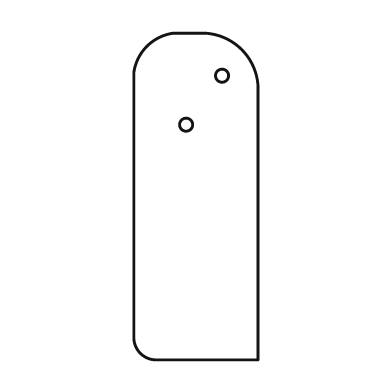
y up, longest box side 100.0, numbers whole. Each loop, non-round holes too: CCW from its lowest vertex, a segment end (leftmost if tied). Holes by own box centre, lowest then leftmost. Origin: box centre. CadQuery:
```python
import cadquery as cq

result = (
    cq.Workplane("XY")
    .moveTo(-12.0, -50.0)
    .lineTo(19.0, -50.0)
    .lineTo(19.0, 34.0)
    .threePointArc((14.0, 45.0), (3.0, 50.0))
    .lineTo(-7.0, 50.0)
    .threePointArc((-15.0, 46.0), (-19.0, 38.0))
    .lineTo(-19.0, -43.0)
    .threePointArc((-17.0, -48.0), (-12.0, -50.0))
    .close()
    .moveTo(-3.0, 22.0)
    .circle(2.0)
    .moveTo(8.0, 37.0)
    .circle(2.0)
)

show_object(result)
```